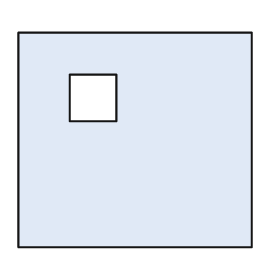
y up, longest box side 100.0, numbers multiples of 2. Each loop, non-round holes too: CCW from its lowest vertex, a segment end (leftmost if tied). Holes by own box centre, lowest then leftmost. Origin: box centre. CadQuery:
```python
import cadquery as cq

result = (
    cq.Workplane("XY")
    .moveTo(-50.0, -46.0)
    .lineTo(50.0, -46.0)
    .lineTo(50.0, 46.0)
    .lineTo(-50.0, 46.0)
    .close()
    .moveTo(-28.0, 8.0)
    .lineTo(-8.0, 8.0)
    .lineTo(-8.0, 28.0)
    .lineTo(-28.0, 28.0)
    .close()
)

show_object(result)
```